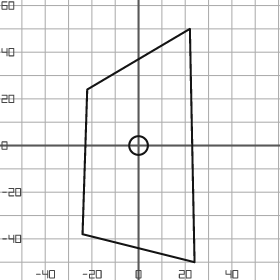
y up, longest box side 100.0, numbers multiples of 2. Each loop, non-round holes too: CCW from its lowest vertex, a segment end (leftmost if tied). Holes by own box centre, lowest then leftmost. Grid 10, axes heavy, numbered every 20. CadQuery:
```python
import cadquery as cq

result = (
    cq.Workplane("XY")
    .moveTo(24.0, -50.0)
    .lineTo(22.0, 50.0)
    .lineTo(-22.0, 24.0)
    .lineTo(-24.0, -38.0)
    .close()
    .moveTo(0.0, 0.0)
    .circle(4.0)
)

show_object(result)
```